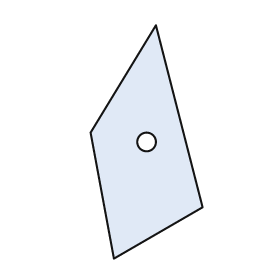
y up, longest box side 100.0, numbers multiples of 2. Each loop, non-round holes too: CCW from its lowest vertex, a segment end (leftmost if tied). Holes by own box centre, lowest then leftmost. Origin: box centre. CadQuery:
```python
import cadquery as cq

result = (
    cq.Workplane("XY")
    .moveTo(-14.0, -50.0)
    .lineTo(24.0, -28.0)
    .lineTo(4.0, 50.0)
    .lineTo(-24.0, 4.0)
    .close()
    .moveTo(0.0, 0.0)
    .circle(4.0)
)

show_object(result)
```